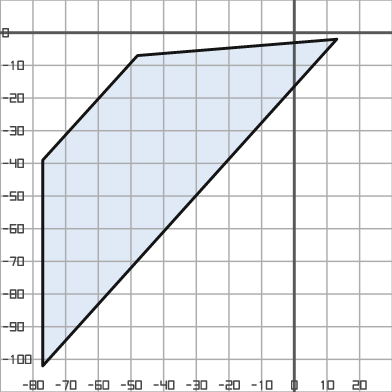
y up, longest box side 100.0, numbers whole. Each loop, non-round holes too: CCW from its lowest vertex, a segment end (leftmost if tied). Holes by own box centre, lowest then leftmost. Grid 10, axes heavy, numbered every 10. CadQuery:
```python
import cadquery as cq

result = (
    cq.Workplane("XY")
    .moveTo(-77.0, -102.0)
    .lineTo(13.0, -2.0)
    .lineTo(-48.0, -7.0)
    .lineTo(-77.0, -39.0)
    .close()
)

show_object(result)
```